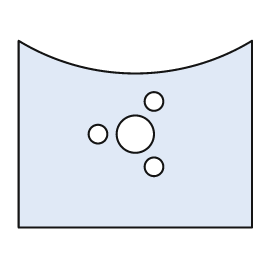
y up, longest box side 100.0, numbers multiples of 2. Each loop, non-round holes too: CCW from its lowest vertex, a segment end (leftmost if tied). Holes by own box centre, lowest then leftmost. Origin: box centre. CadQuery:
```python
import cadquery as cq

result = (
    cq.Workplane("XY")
    .moveTo(-50.0, -40.0)
    .lineTo(50.0, -40.0)
    .lineTo(50.0, 40.0)
    .threePointArc((0.0, 26.0), (-50.0, 40.0))
    .close()
    .moveTo(8.0, -14.0)
    .circle(4.0)
    .moveTo(-16.0, 0.0)
    .circle(4.0)
    .moveTo(0.0, 0.0)
    .circle(8.0)
    .moveTo(8.0, 14.0)
    .circle(4.0)
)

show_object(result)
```